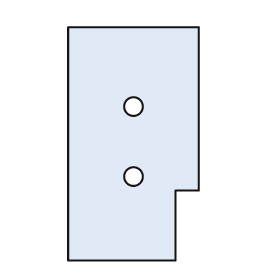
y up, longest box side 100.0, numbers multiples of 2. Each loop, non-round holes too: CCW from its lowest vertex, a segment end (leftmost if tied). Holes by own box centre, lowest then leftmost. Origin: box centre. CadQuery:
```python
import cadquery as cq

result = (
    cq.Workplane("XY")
    .moveTo(-28.0, -50.0)
    .lineTo(18.0, -50.0)
    .lineTo(18.0, -20.0)
    .lineTo(28.0, -20.0)
    .lineTo(28.0, 50.0)
    .lineTo(-28.0, 50.0)
    .close()
    .moveTo(0.0, -14.0)
    .circle(4.0)
    .moveTo(0.0, 16.0)
    .circle(4.0)
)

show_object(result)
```